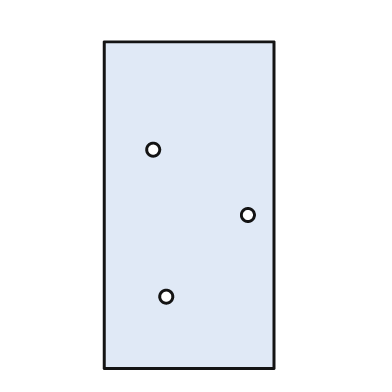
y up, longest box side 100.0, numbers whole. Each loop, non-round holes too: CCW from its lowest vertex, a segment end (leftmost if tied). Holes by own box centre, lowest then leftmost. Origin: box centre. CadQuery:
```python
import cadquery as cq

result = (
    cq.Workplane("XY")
    .moveTo(-26.0, -50.0)
    .lineTo(26.0, -50.0)
    .lineTo(26.0, 50.0)
    .lineTo(-26.0, 50.0)
    .close()
    .moveTo(-7.0, -28.0)
    .circle(2.0)
    .moveTo(18.0, -3.0)
    .circle(2.0)
    .moveTo(-11.0, 17.0)
    .circle(2.0)
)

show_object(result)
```